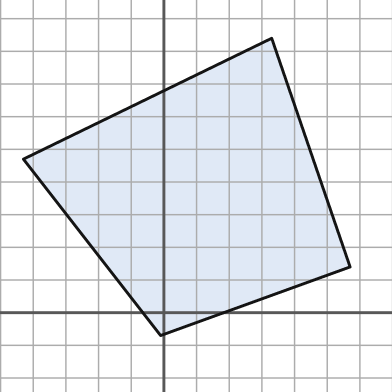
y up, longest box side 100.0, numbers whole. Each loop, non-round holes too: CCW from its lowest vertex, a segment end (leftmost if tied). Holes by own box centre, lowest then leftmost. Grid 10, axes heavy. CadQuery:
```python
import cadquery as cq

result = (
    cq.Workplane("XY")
    .moveTo(-1.0, -7.0)
    .lineTo(57.0, 14.0)
    .lineTo(33.0, 84.0)
    .lineTo(-43.0, 47.0)
    .close()
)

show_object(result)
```